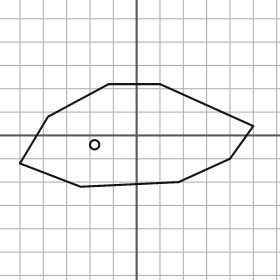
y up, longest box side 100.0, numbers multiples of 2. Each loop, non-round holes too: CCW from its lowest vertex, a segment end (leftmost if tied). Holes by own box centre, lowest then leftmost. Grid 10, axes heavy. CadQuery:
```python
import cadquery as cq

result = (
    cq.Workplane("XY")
    .moveTo(-24.0, -22.0)
    .lineTo(18.0, -20.0)
    .lineTo(40.0, -10.0)
    .lineTo(50.0, 4.0)
    .lineTo(10.0, 22.0)
    .lineTo(-12.0, 22.0)
    .lineTo(-38.0, 8.0)
    .lineTo(-50.0, -12.0)
    .close()
    .moveTo(-18.0, -4.0)
    .circle(2.0)
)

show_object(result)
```